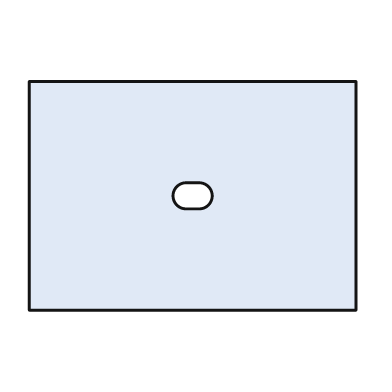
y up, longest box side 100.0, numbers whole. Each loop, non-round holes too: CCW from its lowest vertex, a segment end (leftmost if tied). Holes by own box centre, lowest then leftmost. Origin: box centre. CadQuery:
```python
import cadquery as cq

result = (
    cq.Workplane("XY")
    .moveTo(-50.0, -35.0)
    .lineTo(50.0, -35.0)
    .lineTo(50.0, 35.0)
    .lineTo(-50.0, 35.0)
    .close()
    .moveTo(-2.0, -4.0)
    .lineTo(2.0, -4.0)
    .threePointArc((6.0, 0.0), (2.0, 4.0))
    .lineTo(-2.0, 4.0)
    .threePointArc((-6.0, 0.0), (-2.0, -4.0))
    .close()
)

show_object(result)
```